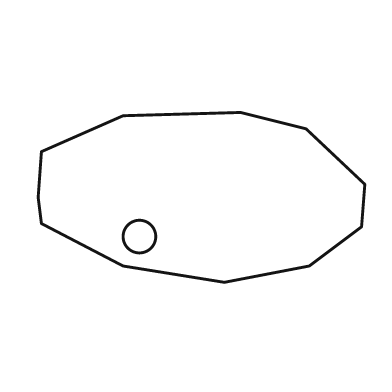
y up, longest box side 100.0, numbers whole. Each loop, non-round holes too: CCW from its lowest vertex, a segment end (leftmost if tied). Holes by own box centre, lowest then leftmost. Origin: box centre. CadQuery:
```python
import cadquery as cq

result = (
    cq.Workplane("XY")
    .moveTo(7.0, -26.0)
    .lineTo(33.0, -21.0)
    .lineTo(49.0, -9.0)
    .lineTo(50.0, 4.0)
    .lineTo(32.0, 21.0)
    .lineTo(12.0, 26.0)
    .lineTo(-24.0, 25.0)
    .lineTo(-49.0, 14.0)
    .lineTo(-50.0, 0.0)
    .lineTo(-49.0, -8.0)
    .lineTo(-24.0, -21.0)
    .close()
    .moveTo(-19.0, -12.0)
    .circle(5.0)
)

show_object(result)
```